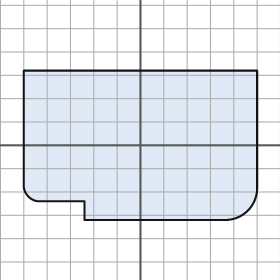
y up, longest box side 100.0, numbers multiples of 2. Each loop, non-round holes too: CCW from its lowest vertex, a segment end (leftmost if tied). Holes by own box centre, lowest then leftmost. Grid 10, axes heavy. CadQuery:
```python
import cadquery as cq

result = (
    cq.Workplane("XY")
    .moveTo(-24.0, -32.0)
    .lineTo(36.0, -32.0)
    .threePointArc((46.0, -28.0), (50.0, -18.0))
    .lineTo(50.0, 32.0)
    .lineTo(-50.0, 32.0)
    .lineTo(-50.0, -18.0)
    .threePointArc((-48.0, -22.0), (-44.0, -24.0))
    .lineTo(-24.0, -24.0)
    .close()
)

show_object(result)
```